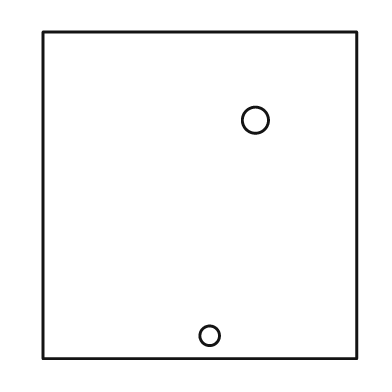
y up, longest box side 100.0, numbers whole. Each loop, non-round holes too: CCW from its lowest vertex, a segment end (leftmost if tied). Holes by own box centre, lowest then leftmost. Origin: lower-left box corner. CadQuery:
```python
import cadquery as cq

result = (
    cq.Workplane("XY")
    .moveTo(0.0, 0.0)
    .lineTo(96.0, 0.0)
    .lineTo(96.0, 100.0)
    .lineTo(0.0, 100.0)
    .close()
    .moveTo(51.0, 7.0)
    .circle(3.0)
    .moveTo(65.0, 73.0)
    .circle(4.0)
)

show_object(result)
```